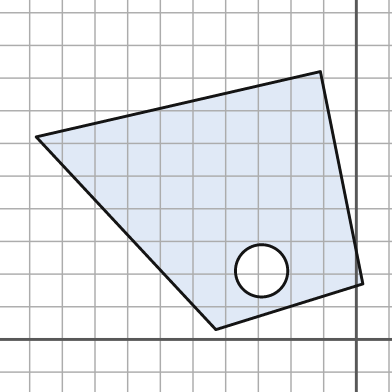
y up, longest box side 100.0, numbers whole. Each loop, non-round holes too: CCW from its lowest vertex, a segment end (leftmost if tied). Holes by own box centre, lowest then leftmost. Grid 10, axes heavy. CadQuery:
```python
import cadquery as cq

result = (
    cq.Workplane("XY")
    .moveTo(-43.0, 3.0)
    .lineTo(2.0, 17.0)
    .lineTo(-11.0, 82.0)
    .lineTo(-98.0, 62.0)
    .close()
    .moveTo(-29.0, 21.0)
    .circle(8.0)
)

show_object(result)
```